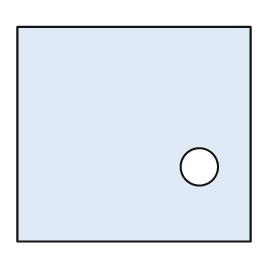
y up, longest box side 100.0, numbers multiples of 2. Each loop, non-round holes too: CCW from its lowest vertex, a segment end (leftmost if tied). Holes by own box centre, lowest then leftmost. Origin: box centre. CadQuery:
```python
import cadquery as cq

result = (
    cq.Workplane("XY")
    .moveTo(-50.0, -46.0)
    .lineTo(50.0, -46.0)
    .lineTo(50.0, 46.0)
    .lineTo(-50.0, 46.0)
    .close()
    .moveTo(28.0, -14.0)
    .circle(8.0)
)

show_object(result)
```